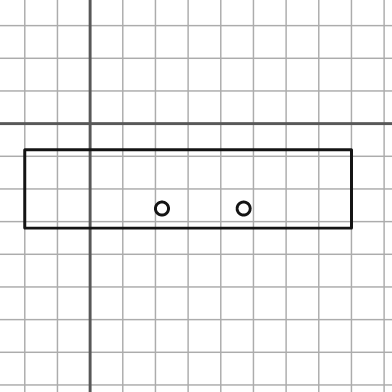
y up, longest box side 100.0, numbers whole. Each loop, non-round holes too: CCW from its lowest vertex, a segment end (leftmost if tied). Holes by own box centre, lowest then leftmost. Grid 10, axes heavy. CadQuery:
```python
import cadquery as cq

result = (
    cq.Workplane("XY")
    .moveTo(-20.0, -32.0)
    .lineTo(80.0, -32.0)
    .lineTo(80.0, -8.0)
    .lineTo(-20.0, -8.0)
    .close()
    .moveTo(22.0, -26.0)
    .circle(2.0)
    .moveTo(47.0, -26.0)
    .circle(2.0)
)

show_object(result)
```